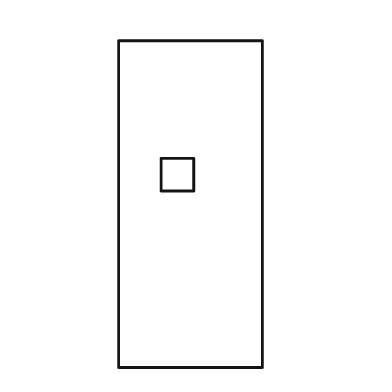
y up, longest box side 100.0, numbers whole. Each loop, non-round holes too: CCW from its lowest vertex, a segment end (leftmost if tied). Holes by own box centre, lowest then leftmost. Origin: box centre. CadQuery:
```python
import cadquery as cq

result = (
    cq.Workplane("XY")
    .moveTo(-22.0, -50.0)
    .lineTo(22.0, -50.0)
    .lineTo(22.0, 50.0)
    .lineTo(-22.0, 50.0)
    .close()
    .moveTo(-9.0, 4.0)
    .lineTo(1.0, 4.0)
    .lineTo(1.0, 14.0)
    .lineTo(-9.0, 14.0)
    .close()
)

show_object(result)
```